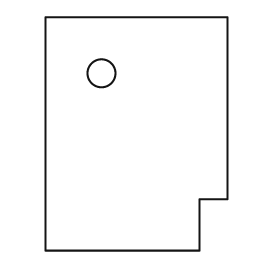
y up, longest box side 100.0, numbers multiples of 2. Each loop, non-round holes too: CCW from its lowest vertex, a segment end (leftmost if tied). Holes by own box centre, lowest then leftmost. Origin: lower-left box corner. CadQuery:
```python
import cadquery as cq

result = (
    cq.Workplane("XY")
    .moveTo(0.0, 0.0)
    .lineTo(66.0, 0.0)
    .lineTo(66.0, 22.0)
    .lineTo(78.0, 22.0)
    .lineTo(78.0, 100.0)
    .lineTo(0.0, 100.0)
    .close()
    .moveTo(24.0, 76.0)
    .circle(6.0)
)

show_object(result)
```